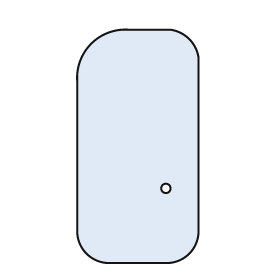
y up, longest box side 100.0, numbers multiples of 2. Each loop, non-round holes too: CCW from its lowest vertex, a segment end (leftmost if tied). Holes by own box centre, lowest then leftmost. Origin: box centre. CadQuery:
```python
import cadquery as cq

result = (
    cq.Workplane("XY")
    .moveTo(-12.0, -50.0)
    .lineTo(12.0, -50.0)
    .threePointArc((22.0, -46.0), (26.0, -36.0))
    .lineTo(26.0, 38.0)
    .threePointArc((22.0, 46.0), (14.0, 50.0))
    .lineTo(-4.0, 50.0)
    .threePointArc((-20.0, 44.0), (-26.0, 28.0))
    .lineTo(-26.0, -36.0)
    .threePointArc((-22.0, -46.0), (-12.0, -50.0))
    .close()
    .moveTo(12.0, -18.0)
    .circle(2.0)
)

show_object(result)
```